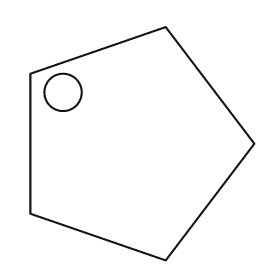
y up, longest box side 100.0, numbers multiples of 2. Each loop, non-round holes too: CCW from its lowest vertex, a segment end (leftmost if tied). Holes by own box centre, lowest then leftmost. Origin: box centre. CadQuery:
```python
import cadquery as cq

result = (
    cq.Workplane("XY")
    .moveTo(10.0, -50.0)
    .lineTo(48.0, 0.0)
    .lineTo(10.0, 50.0)
    .lineTo(-48.0, 30.0)
    .lineTo(-48.0, -30.0)
    .close()
    .moveTo(-34.0, 22.0)
    .circle(8.0)
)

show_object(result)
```